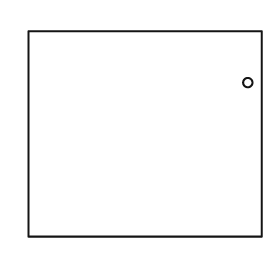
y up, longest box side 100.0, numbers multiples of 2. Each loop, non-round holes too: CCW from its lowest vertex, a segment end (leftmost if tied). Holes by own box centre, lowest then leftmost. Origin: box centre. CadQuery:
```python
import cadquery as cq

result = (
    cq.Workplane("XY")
    .moveTo(-50.0, -44.0)
    .lineTo(50.0, -44.0)
    .lineTo(50.0, 44.0)
    .lineTo(-50.0, 44.0)
    .close()
    .moveTo(44.0, 22.0)
    .circle(2.0)
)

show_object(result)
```